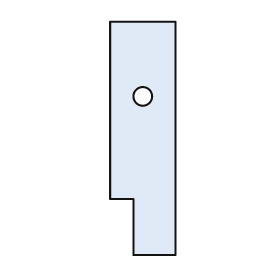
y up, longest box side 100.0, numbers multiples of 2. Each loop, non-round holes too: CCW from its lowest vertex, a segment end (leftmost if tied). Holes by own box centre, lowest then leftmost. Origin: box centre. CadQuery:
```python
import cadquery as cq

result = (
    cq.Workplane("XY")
    .moveTo(-4.0, -50.0)
    .lineTo(14.0, -50.0)
    .lineTo(14.0, 50.0)
    .lineTo(-14.0, 50.0)
    .lineTo(-14.0, -26.0)
    .lineTo(-4.0, -26.0)
    .close()
    .moveTo(0.0, 18.0)
    .circle(4.0)
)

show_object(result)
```